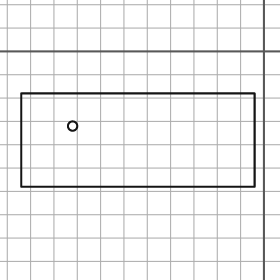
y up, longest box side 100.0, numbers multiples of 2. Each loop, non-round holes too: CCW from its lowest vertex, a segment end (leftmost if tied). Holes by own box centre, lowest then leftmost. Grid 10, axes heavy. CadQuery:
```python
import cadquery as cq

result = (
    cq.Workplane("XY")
    .moveTo(-104.0, -58.0)
    .lineTo(-4.0, -58.0)
    .lineTo(-4.0, -18.0)
    .lineTo(-104.0, -18.0)
    .close()
    .moveTo(-82.0, -32.0)
    .circle(2.0)
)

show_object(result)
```